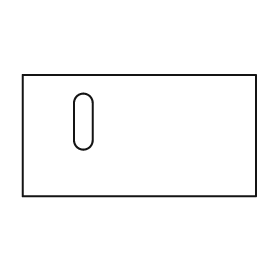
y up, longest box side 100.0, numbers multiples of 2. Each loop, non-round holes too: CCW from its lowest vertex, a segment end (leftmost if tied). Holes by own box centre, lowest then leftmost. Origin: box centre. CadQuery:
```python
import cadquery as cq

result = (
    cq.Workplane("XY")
    .moveTo(-50.0, -26.0)
    .lineTo(50.0, -26.0)
    .lineTo(50.0, 26.0)
    .lineTo(-50.0, 26.0)
    .close()
    .moveTo(-28.0, -2.0)
    .threePointArc((-24.0, -6.0), (-20.0, -2.0))
    .lineTo(-20.0, 14.0)
    .threePointArc((-24.0, 18.0), (-28.0, 14.0))
    .close()
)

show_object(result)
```